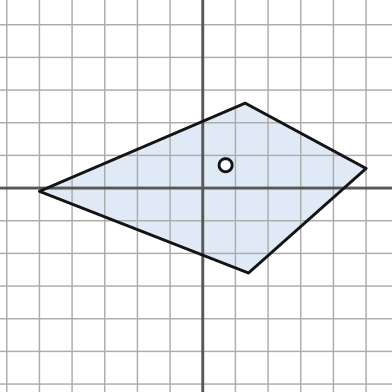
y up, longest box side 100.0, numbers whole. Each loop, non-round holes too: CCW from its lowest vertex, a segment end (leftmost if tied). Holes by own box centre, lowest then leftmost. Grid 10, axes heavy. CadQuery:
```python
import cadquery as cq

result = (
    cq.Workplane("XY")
    .moveTo(14.0, -26.0)
    .lineTo(50.0, 6.0)
    .lineTo(13.0, 26.0)
    .lineTo(-50.0, -1.0)
    .close()
    .moveTo(7.0, 7.0)
    .circle(2.0)
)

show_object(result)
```